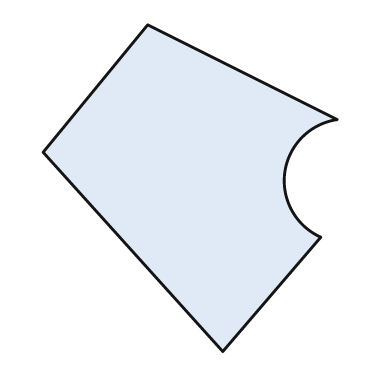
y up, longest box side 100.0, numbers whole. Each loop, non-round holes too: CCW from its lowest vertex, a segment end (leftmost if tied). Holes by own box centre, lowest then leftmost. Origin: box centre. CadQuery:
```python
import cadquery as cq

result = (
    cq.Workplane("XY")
    .moveTo(10.0, -50.0)
    .lineTo(40.0, -15.0)
    .threePointArc((29.0, 5.0), (45.0, 21.0))
    .lineTo(-13.0, 50.0)
    .lineTo(-45.0, 11.0)
    .close()
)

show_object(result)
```